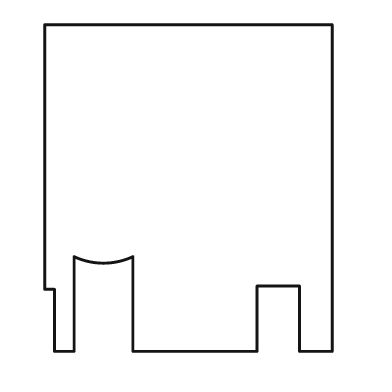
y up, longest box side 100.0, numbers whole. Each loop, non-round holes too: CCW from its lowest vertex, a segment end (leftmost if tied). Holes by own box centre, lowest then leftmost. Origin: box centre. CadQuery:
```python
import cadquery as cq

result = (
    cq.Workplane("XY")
    .moveTo(-41.0, -50.0)
    .lineTo(-35.0, -50.0)
    .lineTo(-35.0, -21.0)
    .threePointArc((-26.0, -23.0), (-17.0, -21.0))
    .lineTo(-17.0, -50.0)
    .lineTo(21.0, -50.0)
    .lineTo(21.0, -30.0)
    .lineTo(34.0, -30.0)
    .lineTo(34.0, -50.0)
    .lineTo(44.0, -50.0)
    .lineTo(44.0, 50.0)
    .lineTo(-44.0, 50.0)
    .lineTo(-44.0, -31.0)
    .lineTo(-41.0, -31.0)
    .close()
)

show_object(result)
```